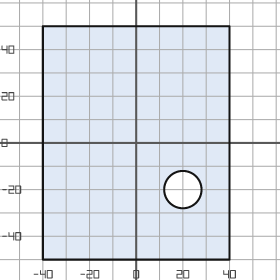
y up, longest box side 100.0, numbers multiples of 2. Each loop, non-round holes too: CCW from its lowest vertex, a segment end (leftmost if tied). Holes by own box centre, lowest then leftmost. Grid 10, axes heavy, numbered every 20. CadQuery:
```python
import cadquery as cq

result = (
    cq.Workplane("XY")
    .moveTo(-40.0, -50.0)
    .lineTo(40.0, -50.0)
    .lineTo(40.0, 50.0)
    .lineTo(-40.0, 50.0)
    .close()
    .moveTo(20.0, -20.0)
    .circle(8.0)
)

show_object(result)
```